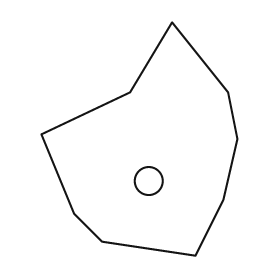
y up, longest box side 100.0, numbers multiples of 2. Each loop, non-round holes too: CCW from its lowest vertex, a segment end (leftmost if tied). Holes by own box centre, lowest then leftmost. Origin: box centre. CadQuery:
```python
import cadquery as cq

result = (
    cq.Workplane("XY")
    .moveTo(24.0, -50.0)
    .lineTo(36.0, -26.0)
    .lineTo(42.0, 0.0)
    .lineTo(38.0, 20.0)
    .lineTo(14.0, 50.0)
    .lineTo(-4.0, 20.0)
    .lineTo(-42.0, 2.0)
    .lineTo(-28.0, -32.0)
    .lineTo(-16.0, -44.0)
    .close()
    .moveTo(4.0, -18.0)
    .circle(6.0)
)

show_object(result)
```